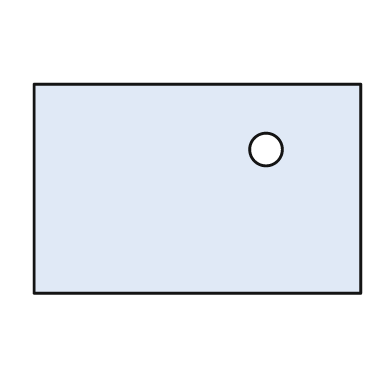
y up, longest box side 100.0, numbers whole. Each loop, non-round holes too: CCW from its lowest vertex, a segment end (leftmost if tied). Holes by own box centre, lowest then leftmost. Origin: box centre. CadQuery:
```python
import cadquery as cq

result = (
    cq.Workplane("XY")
    .moveTo(-50.0, -32.0)
    .lineTo(50.0, -32.0)
    .lineTo(50.0, 32.0)
    .lineTo(-50.0, 32.0)
    .close()
    .moveTo(21.0, 12.0)
    .circle(5.0)
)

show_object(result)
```